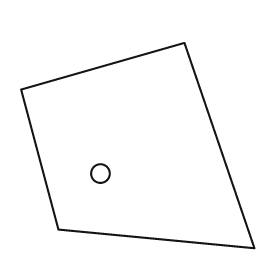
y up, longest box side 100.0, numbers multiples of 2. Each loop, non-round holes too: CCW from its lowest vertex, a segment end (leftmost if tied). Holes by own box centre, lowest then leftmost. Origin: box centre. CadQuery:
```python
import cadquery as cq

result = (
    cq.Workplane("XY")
    .moveTo(50.0, -44.0)
    .lineTo(20.0, 44.0)
    .lineTo(-50.0, 24.0)
    .lineTo(-34.0, -36.0)
    .close()
    .moveTo(-16.0, -12.0)
    .circle(4.0)
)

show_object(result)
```